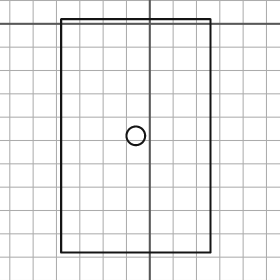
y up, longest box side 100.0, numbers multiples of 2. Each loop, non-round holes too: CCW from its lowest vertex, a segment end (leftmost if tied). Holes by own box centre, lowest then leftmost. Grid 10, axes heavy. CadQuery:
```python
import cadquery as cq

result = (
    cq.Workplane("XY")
    .moveTo(-38.0, -98.0)
    .lineTo(26.0, -98.0)
    .lineTo(26.0, 2.0)
    .lineTo(-38.0, 2.0)
    .close()
    .moveTo(-6.0, -48.0)
    .circle(4.0)
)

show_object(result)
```